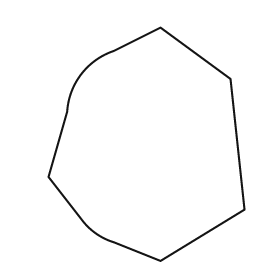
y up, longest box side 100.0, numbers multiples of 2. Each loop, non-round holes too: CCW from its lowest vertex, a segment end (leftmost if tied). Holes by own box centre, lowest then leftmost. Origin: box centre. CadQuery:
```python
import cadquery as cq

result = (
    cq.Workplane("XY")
    .moveTo(6.0, -50.0)
    .lineTo(42.0, -28.0)
    .lineTo(36.0, 28.0)
    .lineTo(6.0, 50.0)
    .lineTo(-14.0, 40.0)
    .threePointArc((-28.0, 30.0), (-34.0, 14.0))
    .lineTo(-42.0, -14.0)
    .lineTo(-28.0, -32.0)
    .threePointArc((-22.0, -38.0), (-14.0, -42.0))
    .close()
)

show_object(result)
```